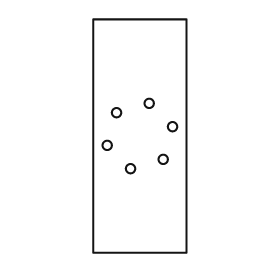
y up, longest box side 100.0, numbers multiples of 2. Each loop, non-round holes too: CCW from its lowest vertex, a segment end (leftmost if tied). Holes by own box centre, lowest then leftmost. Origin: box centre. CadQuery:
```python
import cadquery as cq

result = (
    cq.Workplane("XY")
    .moveTo(-20.0, -50.0)
    .lineTo(20.0, -50.0)
    .lineTo(20.0, 50.0)
    .lineTo(-20.0, 50.0)
    .close()
    .moveTo(-4.0, -14.0)
    .circle(2.0)
    .moveTo(10.0, -10.0)
    .circle(2.0)
    .moveTo(-14.0, -4.0)
    .circle(2.0)
    .moveTo(14.0, 4.0)
    .circle(2.0)
    .moveTo(-10.0, 10.0)
    .circle(2.0)
    .moveTo(4.0, 14.0)
    .circle(2.0)
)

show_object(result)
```